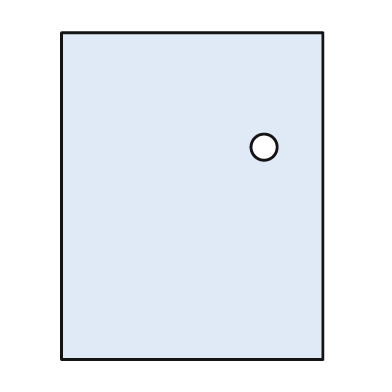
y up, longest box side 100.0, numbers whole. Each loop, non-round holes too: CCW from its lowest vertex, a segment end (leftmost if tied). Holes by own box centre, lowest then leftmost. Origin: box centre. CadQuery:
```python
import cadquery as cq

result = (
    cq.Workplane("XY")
    .moveTo(-40.0, -50.0)
    .lineTo(40.0, -50.0)
    .lineTo(40.0, 50.0)
    .lineTo(-40.0, 50.0)
    .close()
    .moveTo(22.0, 15.0)
    .circle(4.0)
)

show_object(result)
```